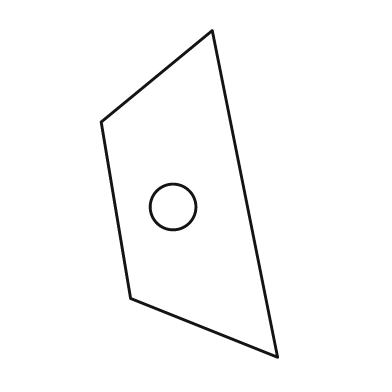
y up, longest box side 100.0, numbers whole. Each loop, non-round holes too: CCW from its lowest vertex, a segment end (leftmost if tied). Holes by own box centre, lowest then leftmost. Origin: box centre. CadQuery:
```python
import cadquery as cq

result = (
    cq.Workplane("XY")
    .moveTo(27.0, -50.0)
    .lineTo(7.0, 50.0)
    .lineTo(-27.0, 22.0)
    .lineTo(-18.0, -32.0)
    .close()
    .moveTo(-5.0, -4.0)
    .circle(7.0)
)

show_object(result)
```